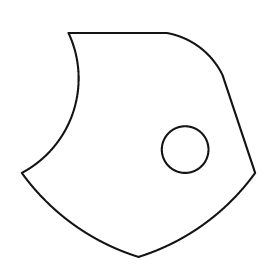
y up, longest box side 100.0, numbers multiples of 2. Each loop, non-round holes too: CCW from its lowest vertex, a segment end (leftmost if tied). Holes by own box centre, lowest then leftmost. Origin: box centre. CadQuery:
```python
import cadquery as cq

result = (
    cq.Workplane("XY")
    .moveTo(0.0, -48.0)
    .threePointArc((28.0, -34.0), (50.0, -12.0))
    .lineTo(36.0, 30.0)
    .threePointArc((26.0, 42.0), (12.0, 48.0))
    .lineTo(-30.0, 48.0)
    .threePointArc((-28.0, 14.0), (-50.0, -12.0))
    .threePointArc((-28.0, -34.0), (0.0, -48.0))
    .close()
    .moveTo(20.0, -2.0)
    .circle(10.0)
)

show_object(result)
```